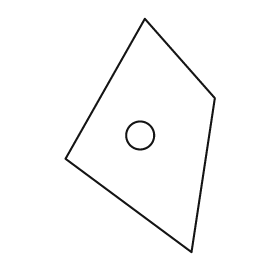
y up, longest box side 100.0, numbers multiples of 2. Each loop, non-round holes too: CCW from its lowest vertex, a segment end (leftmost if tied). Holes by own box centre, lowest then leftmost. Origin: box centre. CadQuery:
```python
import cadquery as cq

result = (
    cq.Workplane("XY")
    .moveTo(22.0, -50.0)
    .lineTo(32.0, 16.0)
    .lineTo(2.0, 50.0)
    .lineTo(-32.0, -10.0)
    .close()
    .moveTo(0.0, 0.0)
    .circle(6.0)
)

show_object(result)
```